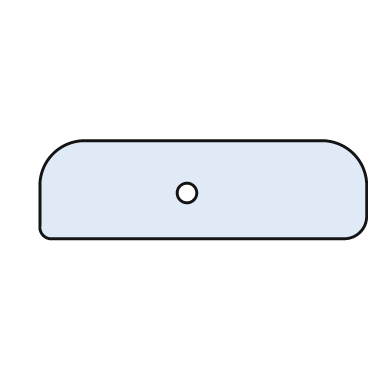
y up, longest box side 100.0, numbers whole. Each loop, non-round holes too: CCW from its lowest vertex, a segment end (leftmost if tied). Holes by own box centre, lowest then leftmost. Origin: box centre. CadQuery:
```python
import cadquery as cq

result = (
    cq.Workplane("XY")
    .moveTo(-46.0, -15.0)
    .lineTo(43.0, -15.0)
    .threePointArc((48.0, -13.0), (50.0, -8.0))
    .lineTo(50.0, 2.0)
    .threePointArc((46.0, 11.0), (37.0, 15.0))
    .lineTo(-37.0, 15.0)
    .threePointArc((-46.0, 11.0), (-50.0, 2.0))
    .lineTo(-50.0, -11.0)
    .threePointArc((-49.0, -14.0), (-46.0, -15.0))
    .close()
    .moveTo(-5.0, -1.0)
    .circle(3.0)
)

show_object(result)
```